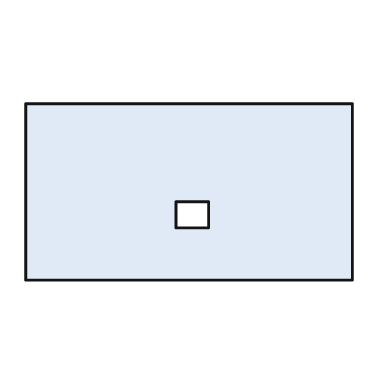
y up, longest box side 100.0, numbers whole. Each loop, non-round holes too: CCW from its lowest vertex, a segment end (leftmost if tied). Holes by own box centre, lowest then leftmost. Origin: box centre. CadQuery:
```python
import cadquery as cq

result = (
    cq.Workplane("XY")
    .moveTo(-50.0, -27.0)
    .lineTo(50.0, -27.0)
    .lineTo(50.0, 27.0)
    .lineTo(-50.0, 27.0)
    .close()
    .moveTo(-4.0, -11.0)
    .lineTo(6.0, -11.0)
    .lineTo(6.0, -3.0)
    .lineTo(-4.0, -3.0)
    .close()
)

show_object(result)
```